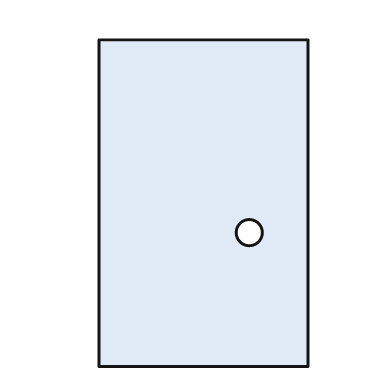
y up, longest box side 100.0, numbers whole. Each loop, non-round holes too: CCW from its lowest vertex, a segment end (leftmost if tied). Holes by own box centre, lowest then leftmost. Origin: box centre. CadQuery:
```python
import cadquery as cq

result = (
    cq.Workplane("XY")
    .moveTo(-32.0, -50.0)
    .lineTo(32.0, -50.0)
    .lineTo(32.0, 50.0)
    .lineTo(-32.0, 50.0)
    .close()
    .moveTo(14.0, -9.0)
    .circle(4.0)
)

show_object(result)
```